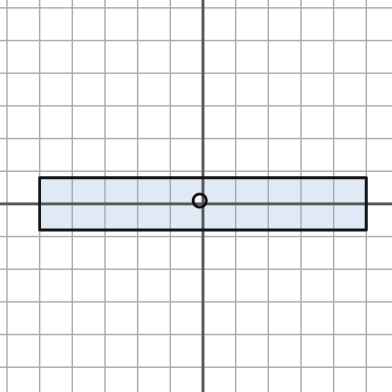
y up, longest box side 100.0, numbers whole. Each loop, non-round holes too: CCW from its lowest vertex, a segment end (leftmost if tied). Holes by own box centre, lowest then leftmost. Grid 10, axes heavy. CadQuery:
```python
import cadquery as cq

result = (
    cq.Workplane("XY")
    .moveTo(-50.0, -8.0)
    .lineTo(50.0, -8.0)
    .lineTo(50.0, 8.0)
    .lineTo(-50.0, 8.0)
    .close()
    .moveTo(-1.0, 1.0)
    .circle(2.0)
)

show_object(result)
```